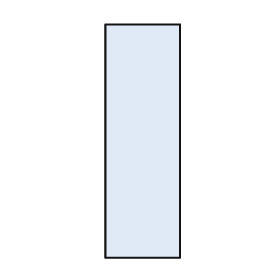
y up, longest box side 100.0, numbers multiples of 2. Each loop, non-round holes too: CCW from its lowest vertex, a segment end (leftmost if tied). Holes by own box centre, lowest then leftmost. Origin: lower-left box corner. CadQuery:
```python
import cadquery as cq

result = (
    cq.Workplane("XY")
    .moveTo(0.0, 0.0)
    .lineTo(32.0, 0.0)
    .lineTo(32.0, 100.0)
    .lineTo(0.0, 100.0)
    .close()
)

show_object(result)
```